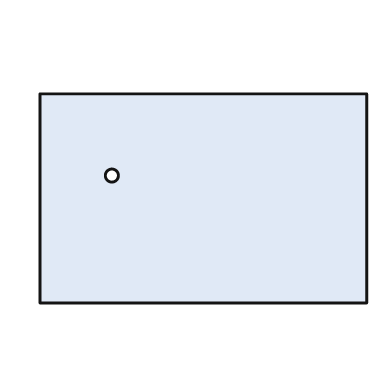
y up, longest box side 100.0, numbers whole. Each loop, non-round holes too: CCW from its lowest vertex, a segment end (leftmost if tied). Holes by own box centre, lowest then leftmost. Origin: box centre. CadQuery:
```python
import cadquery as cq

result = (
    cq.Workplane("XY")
    .moveTo(-50.0, -32.0)
    .lineTo(50.0, -32.0)
    .lineTo(50.0, 32.0)
    .lineTo(-50.0, 32.0)
    .close()
    .moveTo(-28.0, 7.0)
    .circle(2.0)
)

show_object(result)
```